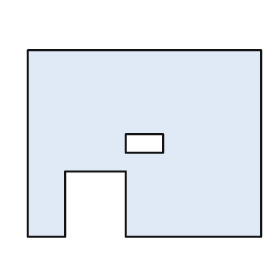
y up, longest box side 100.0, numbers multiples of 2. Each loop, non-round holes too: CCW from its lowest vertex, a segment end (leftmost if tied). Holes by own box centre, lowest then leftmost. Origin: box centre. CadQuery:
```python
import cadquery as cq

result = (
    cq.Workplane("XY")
    .moveTo(-50.0, -40.0)
    .lineTo(-34.0, -40.0)
    .lineTo(-34.0, -12.0)
    .lineTo(-8.0, -12.0)
    .lineTo(-8.0, -40.0)
    .lineTo(50.0, -40.0)
    .lineTo(50.0, 40.0)
    .lineTo(-50.0, 40.0)
    .close()
    .moveTo(-8.0, -4.0)
    .lineTo(8.0, -4.0)
    .lineTo(8.0, 4.0)
    .lineTo(-8.0, 4.0)
    .close()
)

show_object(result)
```